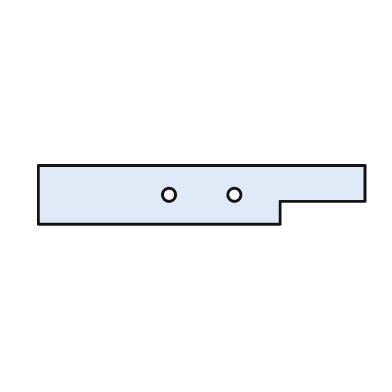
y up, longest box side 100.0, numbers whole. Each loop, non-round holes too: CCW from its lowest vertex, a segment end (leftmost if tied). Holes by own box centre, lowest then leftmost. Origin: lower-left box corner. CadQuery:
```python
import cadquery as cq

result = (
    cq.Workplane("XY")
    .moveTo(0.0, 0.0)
    .lineTo(74.0, 0.0)
    .lineTo(74.0, 7.0)
    .lineTo(100.0, 7.0)
    .lineTo(100.0, 18.0)
    .lineTo(0.0, 18.0)
    .close()
    .moveTo(40.0, 9.0)
    .circle(2.0)
    .moveTo(60.0, 9.0)
    .circle(2.0)
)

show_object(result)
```